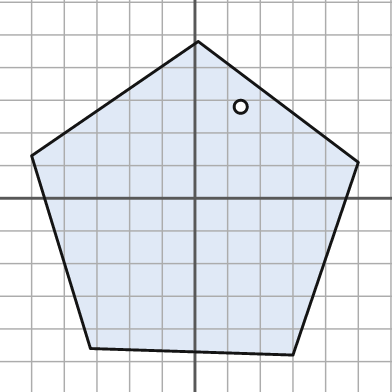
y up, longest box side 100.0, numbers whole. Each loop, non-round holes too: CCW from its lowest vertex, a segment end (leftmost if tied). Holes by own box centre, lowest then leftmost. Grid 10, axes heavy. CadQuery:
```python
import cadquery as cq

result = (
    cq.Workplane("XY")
    .moveTo(30.0, -48.0)
    .lineTo(50.0, 11.0)
    .lineTo(1.0, 48.0)
    .lineTo(-50.0, 13.0)
    .lineTo(-32.0, -46.0)
    .close()
    .moveTo(14.0, 28.0)
    .circle(2.0)
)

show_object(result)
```